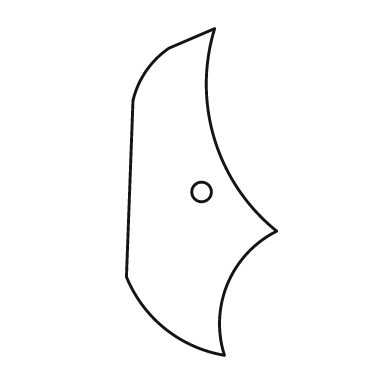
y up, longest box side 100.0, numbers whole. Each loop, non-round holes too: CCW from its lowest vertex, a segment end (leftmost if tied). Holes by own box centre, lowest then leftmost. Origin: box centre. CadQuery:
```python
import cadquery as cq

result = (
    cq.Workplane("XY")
    .moveTo(7.0, -50.0)
    .threePointArc((8.0, -28.0), (23.0, -12.0))
    .threePointArc((4.0, 16.0), (4.0, 50.0))
    .lineTo(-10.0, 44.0)
    .threePointArc((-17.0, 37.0), (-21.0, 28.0))
    .lineTo(-23.0, -26.0)
    .threePointArc((-11.0, -42.0), (7.0, -50.0))
    .close()
    .moveTo(0.0, 0.0)
    .circle(3.0)
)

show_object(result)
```